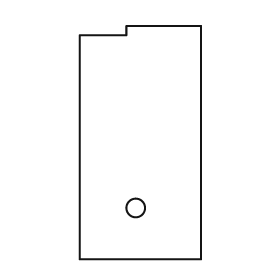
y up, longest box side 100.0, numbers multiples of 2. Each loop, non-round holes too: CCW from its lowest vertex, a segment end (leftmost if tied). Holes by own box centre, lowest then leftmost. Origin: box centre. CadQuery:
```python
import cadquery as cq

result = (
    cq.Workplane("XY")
    .moveTo(-26.0, -50.0)
    .lineTo(26.0, -50.0)
    .lineTo(26.0, 50.0)
    .lineTo(-6.0, 50.0)
    .lineTo(-6.0, 46.0)
    .lineTo(-26.0, 46.0)
    .close()
    .moveTo(-2.0, -28.0)
    .circle(4.0)
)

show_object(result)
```